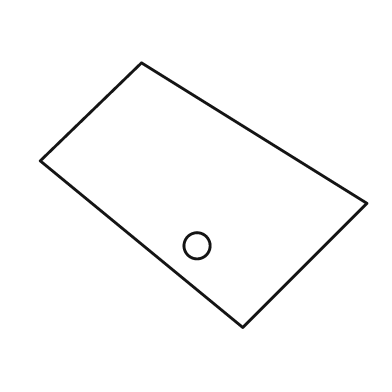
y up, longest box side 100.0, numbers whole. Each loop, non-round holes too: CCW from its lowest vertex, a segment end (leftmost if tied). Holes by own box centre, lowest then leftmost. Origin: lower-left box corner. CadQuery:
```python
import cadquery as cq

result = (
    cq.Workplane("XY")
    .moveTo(62.0, 0.0)
    .lineTo(100.0, 38.0)
    .lineTo(31.0, 81.0)
    .lineTo(0.0, 51.0)
    .close()
    .moveTo(48.0, 25.0)
    .circle(4.0)
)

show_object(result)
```